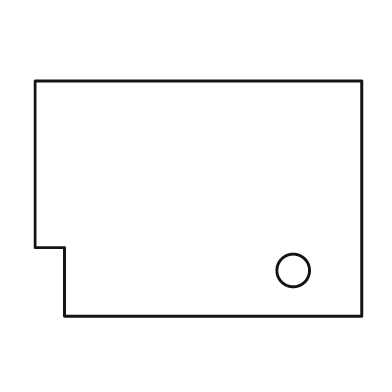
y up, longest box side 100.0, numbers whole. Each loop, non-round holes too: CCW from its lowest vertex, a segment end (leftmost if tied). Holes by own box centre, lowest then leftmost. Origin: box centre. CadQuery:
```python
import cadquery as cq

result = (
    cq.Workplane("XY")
    .moveTo(-41.0, -36.0)
    .lineTo(50.0, -36.0)
    .lineTo(50.0, 36.0)
    .lineTo(-50.0, 36.0)
    .lineTo(-50.0, -15.0)
    .lineTo(-41.0, -15.0)
    .close()
    .moveTo(29.0, -22.0)
    .circle(5.0)
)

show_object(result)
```